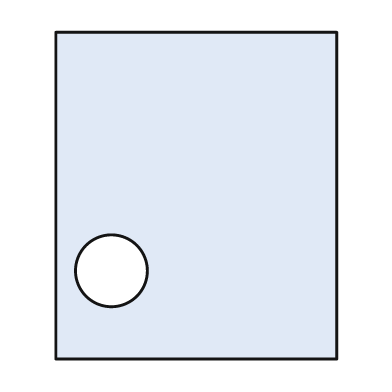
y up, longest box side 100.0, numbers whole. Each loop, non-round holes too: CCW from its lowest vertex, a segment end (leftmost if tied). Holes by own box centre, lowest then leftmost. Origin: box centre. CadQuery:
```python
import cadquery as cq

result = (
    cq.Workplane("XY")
    .moveTo(-43.0, -50.0)
    .lineTo(43.0, -50.0)
    .lineTo(43.0, 50.0)
    .lineTo(-43.0, 50.0)
    .close()
    .moveTo(-26.0, -23.0)
    .circle(11.0)
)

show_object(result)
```